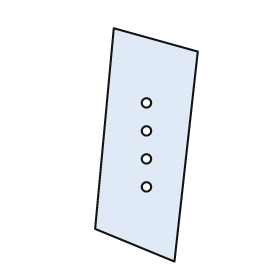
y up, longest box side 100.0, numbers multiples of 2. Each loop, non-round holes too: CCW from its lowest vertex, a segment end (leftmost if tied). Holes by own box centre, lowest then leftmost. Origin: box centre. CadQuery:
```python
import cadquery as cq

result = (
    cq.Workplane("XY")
    .moveTo(12.0, -50.0)
    .lineTo(22.0, 40.0)
    .lineTo(-14.0, 50.0)
    .lineTo(-22.0, -36.0)
    .close()
    .moveTo(0.0, -18.0)
    .circle(2.0)
    .moveTo(0.0, -6.0)
    .circle(2.0)
    .moveTo(0.0, 6.0)
    .circle(2.0)
    .moveTo(0.0, 18.0)
    .circle(2.0)
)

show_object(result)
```